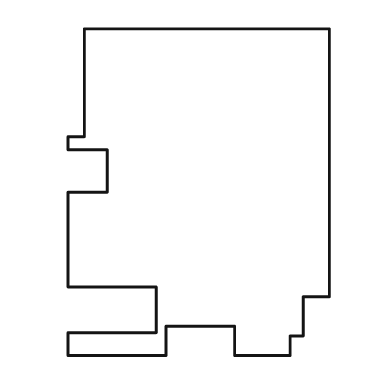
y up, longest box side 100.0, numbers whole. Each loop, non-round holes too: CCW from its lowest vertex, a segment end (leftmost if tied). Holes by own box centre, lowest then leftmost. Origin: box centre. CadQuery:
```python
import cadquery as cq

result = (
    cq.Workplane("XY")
    .moveTo(-40.0, -50.0)
    .lineTo(-10.0, -50.0)
    .lineTo(-10.0, -41.0)
    .lineTo(11.0, -41.0)
    .lineTo(11.0, -50.0)
    .lineTo(28.0, -50.0)
    .lineTo(28.0, -44.0)
    .lineTo(32.0, -44.0)
    .lineTo(32.0, -32.0)
    .lineTo(40.0, -32.0)
    .lineTo(40.0, 50.0)
    .lineTo(-35.0, 50.0)
    .lineTo(-35.0, 17.0)
    .lineTo(-40.0, 17.0)
    .lineTo(-40.0, 13.0)
    .lineTo(-28.0, 13.0)
    .lineTo(-28.0, 0.0)
    .lineTo(-40.0, 0.0)
    .lineTo(-40.0, -29.0)
    .lineTo(-13.0, -29.0)
    .lineTo(-13.0, -43.0)
    .lineTo(-40.0, -43.0)
    .close()
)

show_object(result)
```